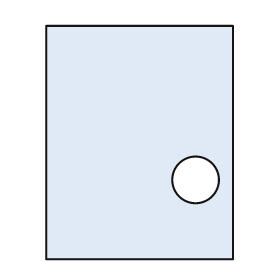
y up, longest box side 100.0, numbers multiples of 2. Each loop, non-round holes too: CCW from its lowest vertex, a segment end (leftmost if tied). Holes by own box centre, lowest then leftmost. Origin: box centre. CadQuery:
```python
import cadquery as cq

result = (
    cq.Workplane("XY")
    .moveTo(-40.0, -50.0)
    .lineTo(40.0, -50.0)
    .lineTo(40.0, 50.0)
    .lineTo(-40.0, 50.0)
    .close()
    .moveTo(24.0, -16.0)
    .circle(10.0)
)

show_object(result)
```